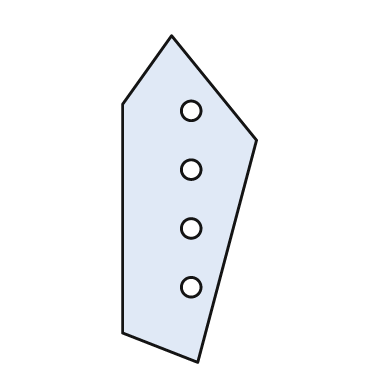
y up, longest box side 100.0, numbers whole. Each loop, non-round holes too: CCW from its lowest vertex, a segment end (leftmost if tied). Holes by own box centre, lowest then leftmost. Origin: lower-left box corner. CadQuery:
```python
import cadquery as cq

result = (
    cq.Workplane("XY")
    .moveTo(23.0, 0.0)
    .lineTo(41.0, 68.0)
    .lineTo(15.0, 100.0)
    .lineTo(0.0, 79.0)
    .lineTo(0.0, 9.0)
    .close()
    .moveTo(21.0, 23.0)
    .circle(3.0)
    .moveTo(21.0, 41.0)
    .circle(3.0)
    .moveTo(21.0, 59.0)
    .circle(3.0)
    .moveTo(21.0, 77.0)
    .circle(3.0)
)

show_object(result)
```